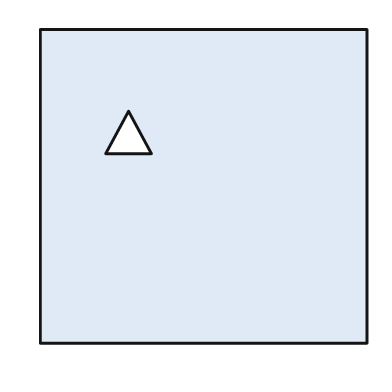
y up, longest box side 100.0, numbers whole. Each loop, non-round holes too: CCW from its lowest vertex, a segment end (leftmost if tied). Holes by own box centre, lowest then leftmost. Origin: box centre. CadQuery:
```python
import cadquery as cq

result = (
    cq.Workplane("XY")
    .moveTo(-50.0, -48.0)
    .lineTo(50.0, -48.0)
    .lineTo(50.0, 48.0)
    .lineTo(-50.0, 48.0)
    .close()
    .moveTo(-30.0, 10.0)
    .lineTo(-16.0, 10.0)
    .lineTo(-23.0, 23.0)
    .close()
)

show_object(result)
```